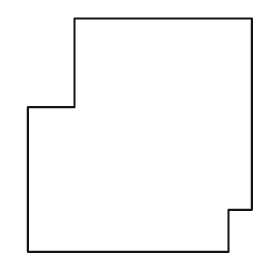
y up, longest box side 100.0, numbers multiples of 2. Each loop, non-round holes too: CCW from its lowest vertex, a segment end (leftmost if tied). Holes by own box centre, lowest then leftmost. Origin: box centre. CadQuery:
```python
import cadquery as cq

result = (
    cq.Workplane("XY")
    .moveTo(-48.0, -50.0)
    .lineTo(38.0, -50.0)
    .lineTo(38.0, -32.0)
    .lineTo(48.0, -32.0)
    .lineTo(48.0, 50.0)
    .lineTo(-28.0, 50.0)
    .lineTo(-28.0, 12.0)
    .lineTo(-48.0, 12.0)
    .close()
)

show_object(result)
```